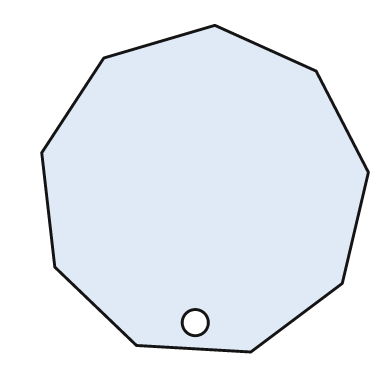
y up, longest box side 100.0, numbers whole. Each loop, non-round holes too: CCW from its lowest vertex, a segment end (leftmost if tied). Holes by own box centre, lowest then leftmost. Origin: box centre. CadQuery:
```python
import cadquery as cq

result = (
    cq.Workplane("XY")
    .moveTo(14.0, -50.0)
    .lineTo(42.0, -29.0)
    .lineTo(50.0, 5.0)
    .lineTo(34.0, 36.0)
    .lineTo(3.0, 50.0)
    .lineTo(-31.0, 40.0)
    .lineTo(-50.0, 11.0)
    .lineTo(-46.0, -24.0)
    .lineTo(-21.0, -48.0)
    .close()
    .moveTo(-3.0, -41.0)
    .circle(4.0)
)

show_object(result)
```